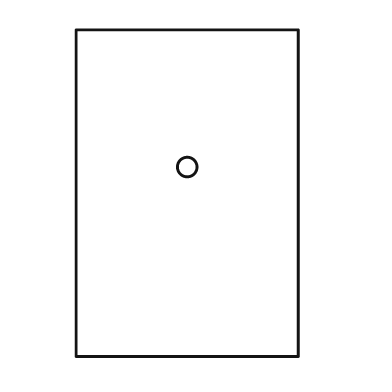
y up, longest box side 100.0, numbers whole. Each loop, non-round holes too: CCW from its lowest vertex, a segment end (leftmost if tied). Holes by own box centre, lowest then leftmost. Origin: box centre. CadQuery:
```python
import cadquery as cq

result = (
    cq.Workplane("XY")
    .moveTo(-34.0, -50.0)
    .lineTo(34.0, -50.0)
    .lineTo(34.0, 50.0)
    .lineTo(-34.0, 50.0)
    .close()
    .moveTo(0.0, 8.0)
    .circle(3.0)
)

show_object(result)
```